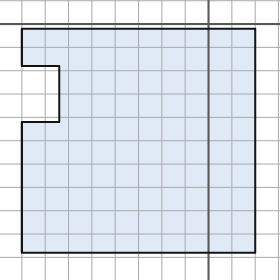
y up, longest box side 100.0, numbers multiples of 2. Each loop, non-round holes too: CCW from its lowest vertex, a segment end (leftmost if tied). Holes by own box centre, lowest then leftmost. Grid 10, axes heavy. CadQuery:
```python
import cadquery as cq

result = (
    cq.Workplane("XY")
    .moveTo(-80.0, -98.0)
    .lineTo(20.0, -98.0)
    .lineTo(20.0, -2.0)
    .lineTo(-80.0, -2.0)
    .lineTo(-80.0, -18.0)
    .lineTo(-64.0, -18.0)
    .lineTo(-64.0, -42.0)
    .lineTo(-80.0, -42.0)
    .close()
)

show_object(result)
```